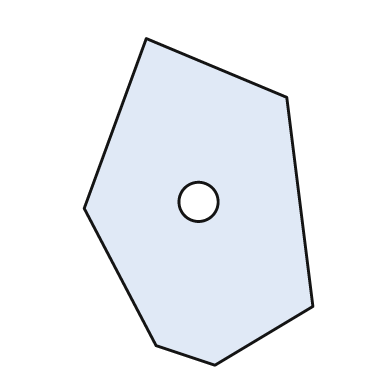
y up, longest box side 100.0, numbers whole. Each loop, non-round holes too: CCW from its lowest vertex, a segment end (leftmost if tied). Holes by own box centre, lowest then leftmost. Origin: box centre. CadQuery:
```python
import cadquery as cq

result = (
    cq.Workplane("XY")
    .moveTo(5.0, -50.0)
    .lineTo(35.0, -32.0)
    .lineTo(27.0, 32.0)
    .lineTo(-16.0, 50.0)
    .lineTo(-35.0, -2.0)
    .lineTo(-13.0, -44.0)
    .close()
    .moveTo(0.0, 0.0)
    .circle(6.0)
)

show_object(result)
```